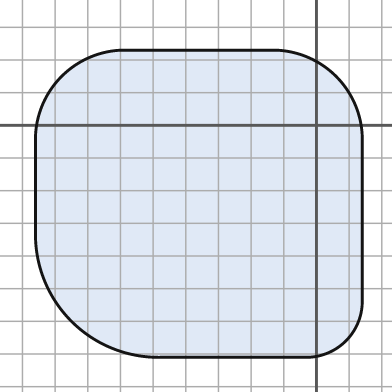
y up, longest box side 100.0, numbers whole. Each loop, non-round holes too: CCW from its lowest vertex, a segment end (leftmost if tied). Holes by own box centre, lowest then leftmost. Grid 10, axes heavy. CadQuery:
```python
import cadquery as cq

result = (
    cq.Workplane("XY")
    .moveTo(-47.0, -71.0)
    .lineTo(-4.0, -71.0)
    .threePointArc((9.0, -66.0), (14.0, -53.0))
    .lineTo(14.0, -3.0)
    .threePointArc((6.0, 15.0), (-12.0, 23.0))
    .lineTo(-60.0, 23.0)
    .threePointArc((-78.0, 15.0), (-86.0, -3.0))
    .lineTo(-86.0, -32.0)
    .threePointArc((-75.0, -60.0), (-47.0, -71.0))
    .close()
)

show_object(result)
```